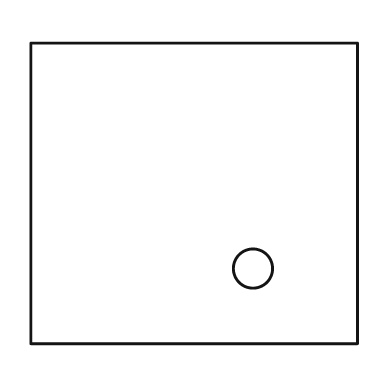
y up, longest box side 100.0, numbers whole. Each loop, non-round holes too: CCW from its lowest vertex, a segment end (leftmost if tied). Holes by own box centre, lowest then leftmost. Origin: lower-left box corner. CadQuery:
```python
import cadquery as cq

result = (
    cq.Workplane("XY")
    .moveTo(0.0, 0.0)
    .lineTo(100.0, 0.0)
    .lineTo(100.0, 92.0)
    .lineTo(0.0, 92.0)
    .close()
    .moveTo(68.0, 23.0)
    .circle(6.0)
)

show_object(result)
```